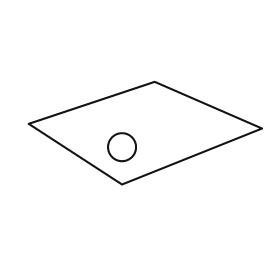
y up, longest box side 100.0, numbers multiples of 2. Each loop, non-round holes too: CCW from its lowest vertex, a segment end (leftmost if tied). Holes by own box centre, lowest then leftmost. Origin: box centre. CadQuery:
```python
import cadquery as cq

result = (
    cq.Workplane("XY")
    .moveTo(-10.0, -22.0)
    .lineTo(50.0, 2.0)
    .lineTo(4.0, 22.0)
    .lineTo(-50.0, 4.0)
    .close()
    .moveTo(-10.0, -6.0)
    .circle(6.0)
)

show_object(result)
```